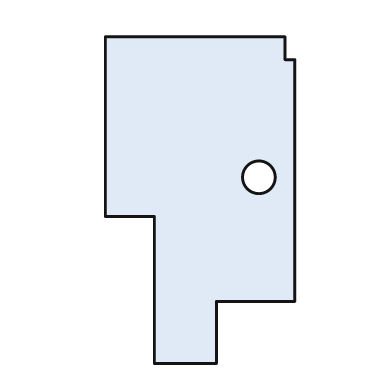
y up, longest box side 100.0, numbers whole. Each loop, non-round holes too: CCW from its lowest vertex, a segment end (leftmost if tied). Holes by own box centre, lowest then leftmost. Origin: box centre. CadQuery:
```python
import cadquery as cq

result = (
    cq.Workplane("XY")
    .moveTo(-14.0, -50.0)
    .lineTo(5.0, -50.0)
    .lineTo(5.0, -31.0)
    .lineTo(29.0, -31.0)
    .lineTo(29.0, 43.0)
    .lineTo(26.0, 43.0)
    .lineTo(26.0, 50.0)
    .lineTo(-29.0, 50.0)
    .lineTo(-29.0, -5.0)
    .lineTo(-14.0, -5.0)
    .close()
    .moveTo(18.0, 7.0)
    .circle(5.0)
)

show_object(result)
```